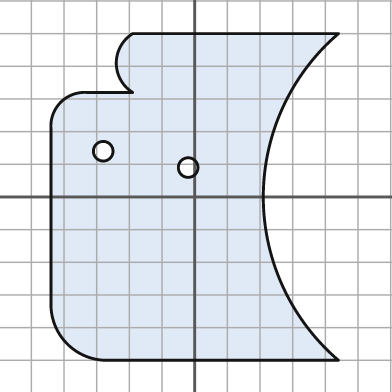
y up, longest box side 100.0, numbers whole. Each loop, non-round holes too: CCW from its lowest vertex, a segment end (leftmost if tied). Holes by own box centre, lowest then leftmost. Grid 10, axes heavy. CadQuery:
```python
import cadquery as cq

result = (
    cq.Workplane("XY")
    .moveTo(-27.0, -50.0)
    .lineTo(44.0, -50.0)
    .threePointArc((21.0, 0.0), (44.0, 50.0))
    .lineTo(-19.0, 50.0)
    .threePointArc((-24.0, 41.0), (-19.0, 32.0))
    .lineTo(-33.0, 32.0)
    .threePointArc((-41.0, 29.0), (-44.0, 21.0))
    .lineTo(-44.0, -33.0)
    .threePointArc((-39.0, -45.0), (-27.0, -50.0))
    .close()
    .moveTo(-2.0, 9.0)
    .circle(3.0)
    .moveTo(-28.0, 14.0)
    .circle(3.0)
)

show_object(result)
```